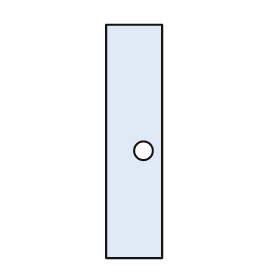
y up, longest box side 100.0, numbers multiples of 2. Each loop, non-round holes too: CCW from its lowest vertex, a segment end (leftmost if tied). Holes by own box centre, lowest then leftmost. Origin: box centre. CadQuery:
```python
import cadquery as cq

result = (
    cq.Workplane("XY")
    .moveTo(-12.0, -50.0)
    .lineTo(12.0, -50.0)
    .lineTo(12.0, 50.0)
    .lineTo(-12.0, 50.0)
    .close()
    .moveTo(4.0, -4.0)
    .circle(4.0)
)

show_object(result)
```